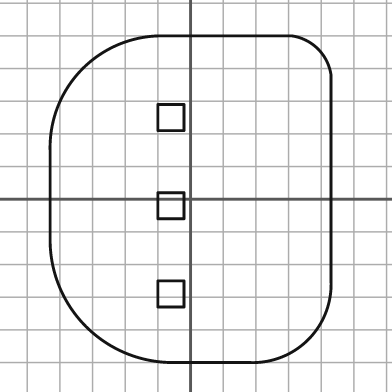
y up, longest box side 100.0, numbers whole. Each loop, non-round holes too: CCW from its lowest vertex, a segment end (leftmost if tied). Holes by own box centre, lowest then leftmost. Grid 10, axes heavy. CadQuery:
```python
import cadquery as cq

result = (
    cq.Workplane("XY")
    .moveTo(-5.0, -50.0)
    .lineTo(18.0, -50.0)
    .threePointArc((36.0, -43.0), (43.0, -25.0))
    .lineTo(43.0, 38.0)
    .threePointArc((39.0, 46.0), (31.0, 50.0))
    .lineTo(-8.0, 50.0)
    .threePointArc((-33.0, 40.0), (-43.0, 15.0))
    .lineTo(-43.0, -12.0)
    .threePointArc((-32.0, -39.0), (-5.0, -50.0))
    .close()
    .moveTo(-10.0, -33.0)
    .lineTo(-2.0, -33.0)
    .lineTo(-2.0, -25.0)
    .lineTo(-10.0, -25.0)
    .close()
    .moveTo(-10.0, -6.0)
    .lineTo(-2.0, -6.0)
    .lineTo(-2.0, 2.0)
    .lineTo(-10.0, 2.0)
    .close()
    .moveTo(-10.0, 21.0)
    .lineTo(-2.0, 21.0)
    .lineTo(-2.0, 29.0)
    .lineTo(-10.0, 29.0)
    .close()
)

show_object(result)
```